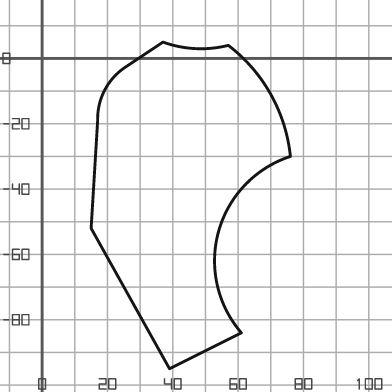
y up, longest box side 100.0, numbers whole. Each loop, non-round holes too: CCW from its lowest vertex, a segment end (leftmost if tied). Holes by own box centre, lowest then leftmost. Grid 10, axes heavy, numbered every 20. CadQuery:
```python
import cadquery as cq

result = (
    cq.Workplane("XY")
    .moveTo(39.0, -95.0)
    .lineTo(61.0, -84.0)
    .threePointArc((54.0, -53.0), (76.0, -30.0))
    .threePointArc((70.0, -11.0), (57.0, 4.0))
    .threePointArc((47.0, 3.0), (37.0, 5.0))
    .lineTo(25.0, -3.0)
    .threePointArc((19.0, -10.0), (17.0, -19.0))
    .lineTo(15.0, -52.0)
    .close()
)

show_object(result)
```